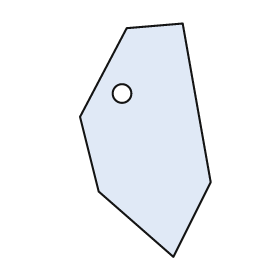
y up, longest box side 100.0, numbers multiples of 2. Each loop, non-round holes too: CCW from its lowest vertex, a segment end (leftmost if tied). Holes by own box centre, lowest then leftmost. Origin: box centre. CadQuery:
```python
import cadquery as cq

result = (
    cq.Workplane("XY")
    .moveTo(12.0, -50.0)
    .lineTo(28.0, -18.0)
    .lineTo(16.0, 50.0)
    .lineTo(-8.0, 48.0)
    .lineTo(-28.0, 10.0)
    .lineTo(-20.0, -22.0)
    .close()
    .moveTo(-10.0, 20.0)
    .circle(4.0)
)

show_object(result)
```